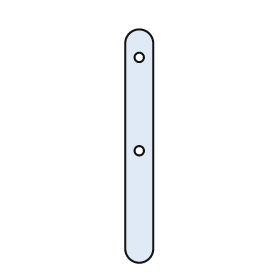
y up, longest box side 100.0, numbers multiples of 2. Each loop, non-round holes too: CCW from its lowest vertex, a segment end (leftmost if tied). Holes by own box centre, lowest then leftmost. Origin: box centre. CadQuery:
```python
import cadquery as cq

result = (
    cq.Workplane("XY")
    .moveTo(-6.0, -44.0)
    .threePointArc((0.0, -50.0), (6.0, -44.0))
    .lineTo(6.0, 44.0)
    .threePointArc((0.0, 50.0), (-6.0, 44.0))
    .close()
    .moveTo(0.0, -2.0)
    .circle(2.0)
    .moveTo(0.0, 38.0)
    .circle(2.0)
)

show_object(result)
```